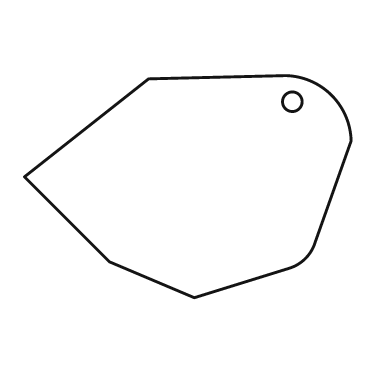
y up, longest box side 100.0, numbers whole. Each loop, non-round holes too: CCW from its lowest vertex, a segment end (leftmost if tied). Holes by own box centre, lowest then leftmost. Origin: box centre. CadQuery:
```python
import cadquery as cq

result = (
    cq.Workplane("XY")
    .moveTo(2.0, -34.0)
    .lineTo(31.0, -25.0)
    .threePointArc((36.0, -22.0), (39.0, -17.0))
    .lineTo(50.0, 14.0)
    .threePointArc((44.0, 28.0), (30.0, 34.0))
    .lineTo(-12.0, 33.0)
    .lineTo(-50.0, 3.0)
    .lineTo(-24.0, -23.0)
    .close()
    .moveTo(32.0, 26.0)
    .circle(3.0)
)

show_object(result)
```